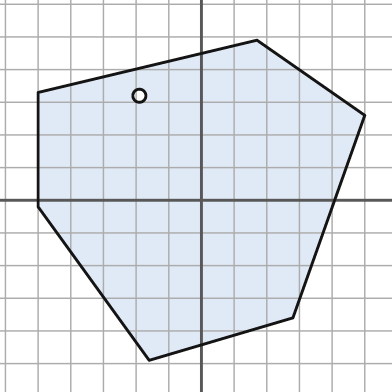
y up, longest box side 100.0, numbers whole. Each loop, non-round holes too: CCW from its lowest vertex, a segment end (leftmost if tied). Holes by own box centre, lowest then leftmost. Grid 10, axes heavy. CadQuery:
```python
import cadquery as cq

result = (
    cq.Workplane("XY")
    .moveTo(-16.0, -49.0)
    .lineTo(28.0, -36.0)
    .lineTo(50.0, 26.0)
    .lineTo(17.0, 49.0)
    .lineTo(-50.0, 33.0)
    .lineTo(-50.0, -2.0)
    .close()
    .moveTo(-19.0, 32.0)
    .circle(2.0)
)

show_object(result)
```